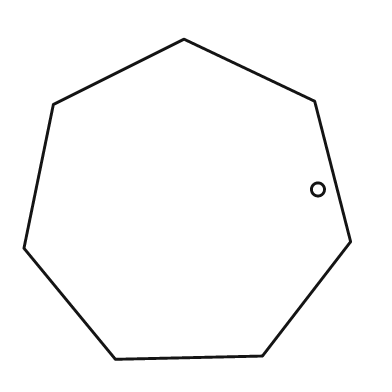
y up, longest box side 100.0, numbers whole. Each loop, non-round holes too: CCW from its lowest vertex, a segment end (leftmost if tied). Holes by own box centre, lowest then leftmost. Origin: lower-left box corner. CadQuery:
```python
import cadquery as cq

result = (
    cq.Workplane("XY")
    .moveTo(28.0, 0.0)
    .lineTo(73.0, 1.0)
    .lineTo(100.0, 36.0)
    .lineTo(89.0, 79.0)
    .lineTo(49.0, 98.0)
    .lineTo(9.0, 78.0)
    .lineTo(0.0, 34.0)
    .close()
    .moveTo(90.0, 52.0)
    .circle(2.0)
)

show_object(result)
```